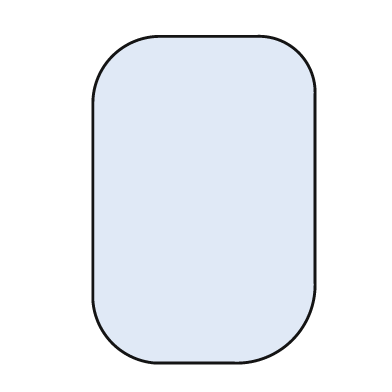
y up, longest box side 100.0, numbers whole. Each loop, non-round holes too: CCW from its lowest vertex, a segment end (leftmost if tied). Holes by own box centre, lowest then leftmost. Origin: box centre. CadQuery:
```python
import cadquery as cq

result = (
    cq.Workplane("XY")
    .moveTo(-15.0, -50.0)
    .lineTo(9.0, -50.0)
    .threePointArc((27.0, -43.0), (34.0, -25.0))
    .lineTo(34.0, 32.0)
    .threePointArc((29.0, 45.0), (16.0, 50.0))
    .lineTo(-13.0, 50.0)
    .threePointArc((-28.0, 44.0), (-34.0, 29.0))
    .lineTo(-34.0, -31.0)
    .threePointArc((-28.0, -44.0), (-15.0, -50.0))
    .close()
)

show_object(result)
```